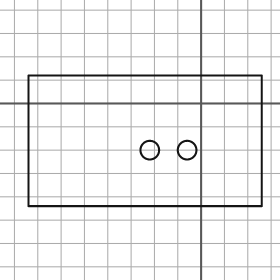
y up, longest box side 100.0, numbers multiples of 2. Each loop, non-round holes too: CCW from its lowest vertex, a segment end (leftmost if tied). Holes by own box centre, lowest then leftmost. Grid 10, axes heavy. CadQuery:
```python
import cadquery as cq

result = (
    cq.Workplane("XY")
    .moveTo(-74.0, -44.0)
    .lineTo(26.0, -44.0)
    .lineTo(26.0, 12.0)
    .lineTo(-74.0, 12.0)
    .close()
    .moveTo(-22.0, -20.0)
    .circle(4.0)
    .moveTo(-6.0, -20.0)
    .circle(4.0)
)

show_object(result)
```